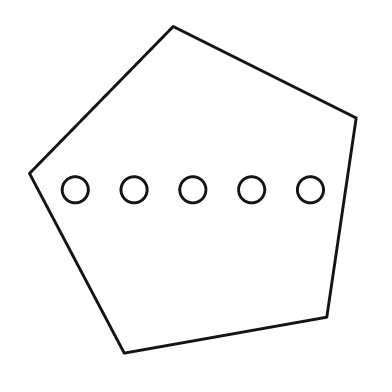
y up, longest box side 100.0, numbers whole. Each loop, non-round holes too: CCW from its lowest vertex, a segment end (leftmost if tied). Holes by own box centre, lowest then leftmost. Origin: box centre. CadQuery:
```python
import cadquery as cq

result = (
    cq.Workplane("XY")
    .moveTo(-21.0, -50.0)
    .lineTo(41.0, -39.0)
    .lineTo(50.0, 22.0)
    .lineTo(-6.0, 50.0)
    .lineTo(-50.0, 5.0)
    .close()
    .moveTo(-36.0, 0.0)
    .circle(4.0)
    .moveTo(-18.0, 0.0)
    .circle(4.0)
    .moveTo(0.0, 0.0)
    .circle(4.0)
    .moveTo(18.0, 0.0)
    .circle(4.0)
    .moveTo(36.0, 0.0)
    .circle(4.0)
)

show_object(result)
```